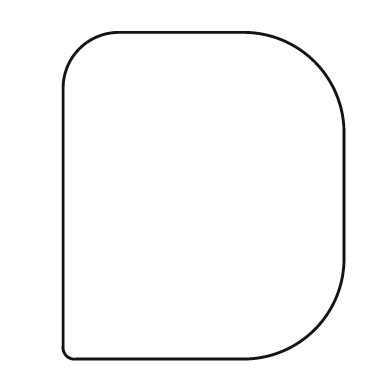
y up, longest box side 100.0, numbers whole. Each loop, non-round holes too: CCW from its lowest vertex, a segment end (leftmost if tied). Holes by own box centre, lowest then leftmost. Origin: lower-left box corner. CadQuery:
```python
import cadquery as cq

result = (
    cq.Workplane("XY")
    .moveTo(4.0, 0.0)
    .lineTo(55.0, 0.0)
    .threePointArc((77.0, 9.0), (86.0, 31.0))
    .lineTo(86.0, 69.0)
    .threePointArc((77.0, 91.0), (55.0, 100.0))
    .lineTo(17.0, 100.0)
    .threePointArc((5.0, 95.0), (0.0, 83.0))
    .lineTo(0.0, 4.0)
    .threePointArc((1.0, 1.0), (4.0, 0.0))
    .close()
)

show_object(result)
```